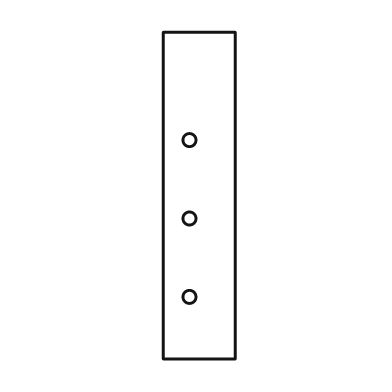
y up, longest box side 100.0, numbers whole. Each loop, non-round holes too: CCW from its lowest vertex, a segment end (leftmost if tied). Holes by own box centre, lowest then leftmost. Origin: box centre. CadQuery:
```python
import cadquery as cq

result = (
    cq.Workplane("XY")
    .moveTo(-11.0, -50.0)
    .lineTo(11.0, -50.0)
    .lineTo(11.0, 50.0)
    .lineTo(-11.0, 50.0)
    .close()
    .moveTo(-3.0, -31.0)
    .circle(2.0)
    .moveTo(-3.0, -7.0)
    .circle(2.0)
    .moveTo(-3.0, 17.0)
    .circle(2.0)
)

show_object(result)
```